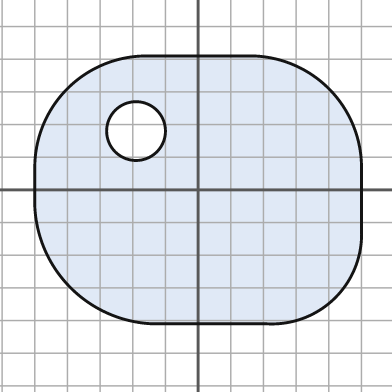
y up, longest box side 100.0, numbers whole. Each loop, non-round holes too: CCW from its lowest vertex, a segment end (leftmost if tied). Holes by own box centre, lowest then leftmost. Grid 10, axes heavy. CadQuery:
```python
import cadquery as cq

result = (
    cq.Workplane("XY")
    .moveTo(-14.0, -41.0)
    .lineTo(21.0, -41.0)
    .threePointArc((42.0, -33.0), (50.0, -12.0))
    .lineTo(50.0, 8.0)
    .threePointArc((40.0, 31.0), (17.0, 41.0))
    .lineTo(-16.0, 41.0)
    .threePointArc((-40.0, 31.0), (-50.0, 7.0))
    .lineTo(-50.0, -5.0)
    .threePointArc((-39.0, -30.0), (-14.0, -41.0))
    .close()
    .moveTo(-19.0, 18.0)
    .circle(9.0)
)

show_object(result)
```